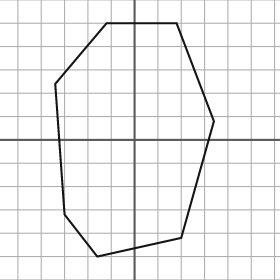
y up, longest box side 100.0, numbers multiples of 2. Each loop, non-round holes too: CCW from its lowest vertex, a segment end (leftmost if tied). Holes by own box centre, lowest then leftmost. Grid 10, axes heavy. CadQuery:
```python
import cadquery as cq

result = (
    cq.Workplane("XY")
    .moveTo(-16.0, -50.0)
    .lineTo(20.0, -42.0)
    .lineTo(34.0, 8.0)
    .lineTo(18.0, 50.0)
    .lineTo(-12.0, 50.0)
    .lineTo(-34.0, 24.0)
    .lineTo(-30.0, -32.0)
    .close()
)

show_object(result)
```